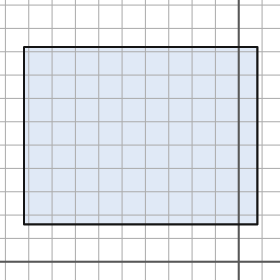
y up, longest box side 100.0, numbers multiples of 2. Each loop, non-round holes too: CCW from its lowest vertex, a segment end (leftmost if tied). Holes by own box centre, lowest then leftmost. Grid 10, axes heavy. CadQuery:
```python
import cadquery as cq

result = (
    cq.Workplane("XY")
    .moveTo(-92.0, 16.0)
    .lineTo(8.0, 16.0)
    .lineTo(8.0, 92.0)
    .lineTo(-92.0, 92.0)
    .close()
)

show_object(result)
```